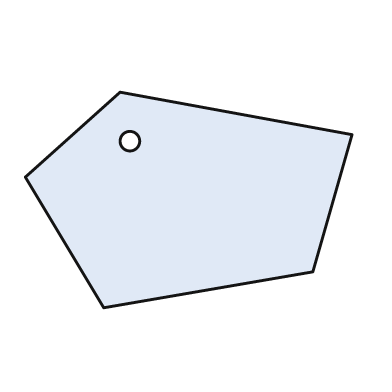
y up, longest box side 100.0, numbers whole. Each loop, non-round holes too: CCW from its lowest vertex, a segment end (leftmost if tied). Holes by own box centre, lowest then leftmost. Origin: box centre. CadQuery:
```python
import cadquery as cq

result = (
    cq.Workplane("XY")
    .moveTo(-26.0, -33.0)
    .lineTo(38.0, -22.0)
    .lineTo(50.0, 20.0)
    .lineTo(-21.0, 33.0)
    .lineTo(-50.0, 7.0)
    .close()
    .moveTo(-18.0, 18.0)
    .circle(3.0)
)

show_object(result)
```